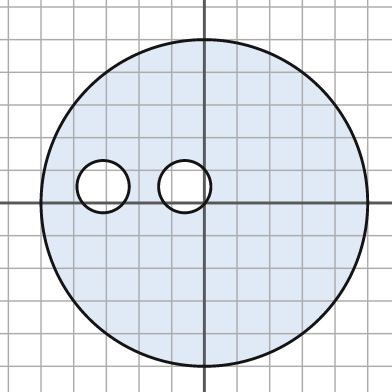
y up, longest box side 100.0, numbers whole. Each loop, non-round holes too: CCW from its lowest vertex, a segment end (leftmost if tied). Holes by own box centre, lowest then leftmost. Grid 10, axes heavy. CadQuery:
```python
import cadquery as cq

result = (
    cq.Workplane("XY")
    .moveTo(0.0, 0.0)
    .circle(50.0)
    .moveTo(-31.0, 5.0)
    .circle(8.0)
    .moveTo(-6.0, 5.0)
    .circle(8.0)
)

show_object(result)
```